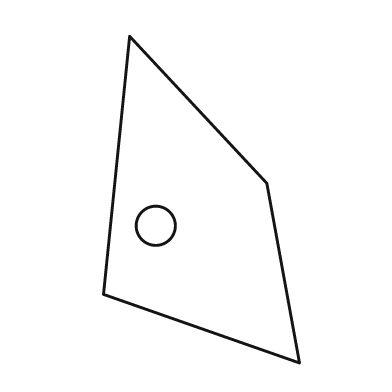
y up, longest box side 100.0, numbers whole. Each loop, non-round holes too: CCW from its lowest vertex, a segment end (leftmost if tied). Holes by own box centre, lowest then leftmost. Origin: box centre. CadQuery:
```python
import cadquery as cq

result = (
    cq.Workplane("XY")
    .moveTo(30.0, -50.0)
    .lineTo(20.0, 5.0)
    .lineTo(-22.0, 50.0)
    .lineTo(-30.0, -29.0)
    .close()
    .moveTo(-14.0, -8.0)
    .circle(6.0)
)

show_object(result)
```